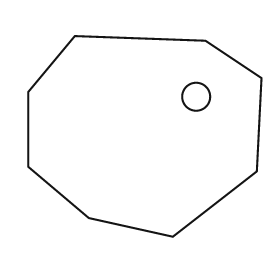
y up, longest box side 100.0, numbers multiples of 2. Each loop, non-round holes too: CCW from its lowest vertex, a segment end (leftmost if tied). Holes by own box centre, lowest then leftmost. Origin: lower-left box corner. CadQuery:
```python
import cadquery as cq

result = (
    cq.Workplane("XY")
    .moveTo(62.0, 0.0)
    .lineTo(98.0, 28.0)
    .lineTo(100.0, 68.0)
    .lineTo(76.0, 84.0)
    .lineTo(20.0, 86.0)
    .lineTo(0.0, 62.0)
    .lineTo(0.0, 30.0)
    .lineTo(26.0, 8.0)
    .close()
    .moveTo(72.0, 60.0)
    .circle(6.0)
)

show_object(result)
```